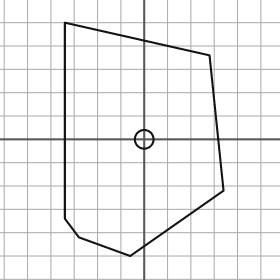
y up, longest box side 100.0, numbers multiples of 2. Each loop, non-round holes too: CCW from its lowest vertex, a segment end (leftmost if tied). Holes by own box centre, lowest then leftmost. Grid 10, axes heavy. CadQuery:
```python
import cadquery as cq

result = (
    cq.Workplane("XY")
    .moveTo(-6.0, -50.0)
    .lineTo(34.0, -22.0)
    .lineTo(28.0, 36.0)
    .lineTo(-34.0, 50.0)
    .lineTo(-34.0, -34.0)
    .lineTo(-28.0, -42.0)
    .close()
    .moveTo(0.0, 0.0)
    .circle(4.0)
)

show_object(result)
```